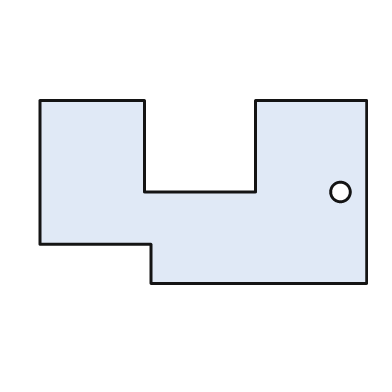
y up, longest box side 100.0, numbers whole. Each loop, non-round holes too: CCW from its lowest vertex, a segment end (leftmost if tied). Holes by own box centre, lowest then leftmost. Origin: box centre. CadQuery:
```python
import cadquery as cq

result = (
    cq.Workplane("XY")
    .moveTo(-16.0, -28.0)
    .lineTo(50.0, -28.0)
    .lineTo(50.0, 28.0)
    .lineTo(16.0, 28.0)
    .lineTo(16.0, 0.0)
    .lineTo(-18.0, 0.0)
    .lineTo(-18.0, 28.0)
    .lineTo(-50.0, 28.0)
    .lineTo(-50.0, -16.0)
    .lineTo(-16.0, -16.0)
    .close()
    .moveTo(42.0, 0.0)
    .circle(3.0)
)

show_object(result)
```